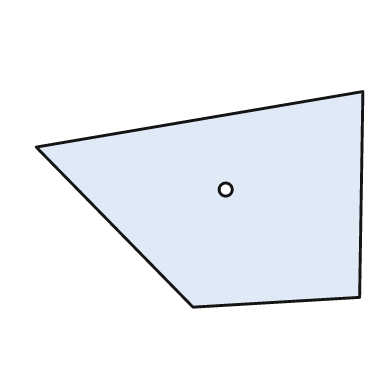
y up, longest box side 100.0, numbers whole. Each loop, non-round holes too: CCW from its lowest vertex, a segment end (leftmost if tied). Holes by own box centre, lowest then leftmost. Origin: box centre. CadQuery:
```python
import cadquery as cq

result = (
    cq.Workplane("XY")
    .moveTo(-2.0, -33.0)
    .lineTo(49.0, -30.0)
    .lineTo(50.0, 33.0)
    .lineTo(-50.0, 16.0)
    .close()
    .moveTo(8.0, 3.0)
    .circle(2.0)
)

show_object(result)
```